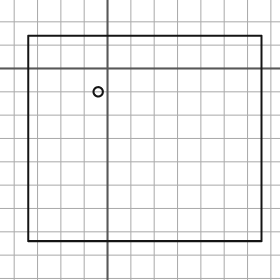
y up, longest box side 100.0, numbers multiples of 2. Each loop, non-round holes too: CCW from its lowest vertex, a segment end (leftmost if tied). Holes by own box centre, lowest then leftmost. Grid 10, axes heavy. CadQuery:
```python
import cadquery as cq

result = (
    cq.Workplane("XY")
    .moveTo(-34.0, -74.0)
    .lineTo(66.0, -74.0)
    .lineTo(66.0, 14.0)
    .lineTo(-34.0, 14.0)
    .close()
    .moveTo(-4.0, -10.0)
    .circle(2.0)
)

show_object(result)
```